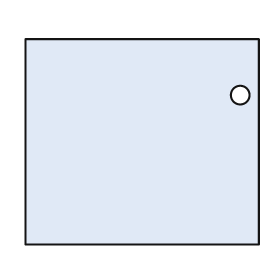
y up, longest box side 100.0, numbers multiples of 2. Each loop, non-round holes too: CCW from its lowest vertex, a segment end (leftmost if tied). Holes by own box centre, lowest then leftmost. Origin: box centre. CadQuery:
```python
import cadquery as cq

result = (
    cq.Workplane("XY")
    .moveTo(-50.0, -44.0)
    .lineTo(50.0, -44.0)
    .lineTo(50.0, 44.0)
    .lineTo(-50.0, 44.0)
    .close()
    .moveTo(42.0, 20.0)
    .circle(4.0)
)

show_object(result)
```